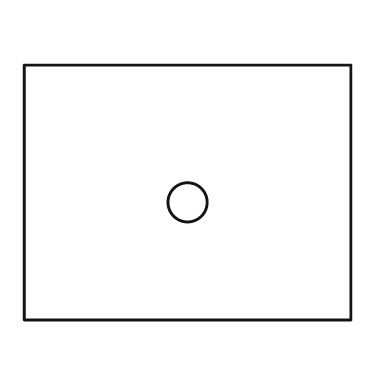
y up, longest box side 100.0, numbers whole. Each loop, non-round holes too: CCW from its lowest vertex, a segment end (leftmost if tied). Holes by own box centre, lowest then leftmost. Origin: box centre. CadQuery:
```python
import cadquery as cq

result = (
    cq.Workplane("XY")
    .moveTo(-50.0, -39.0)
    .lineTo(50.0, -39.0)
    .lineTo(50.0, 39.0)
    .lineTo(-50.0, 39.0)
    .close()
    .moveTo(0.0, -3.0)
    .circle(6.0)
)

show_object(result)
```